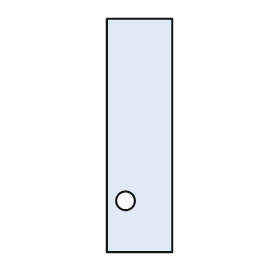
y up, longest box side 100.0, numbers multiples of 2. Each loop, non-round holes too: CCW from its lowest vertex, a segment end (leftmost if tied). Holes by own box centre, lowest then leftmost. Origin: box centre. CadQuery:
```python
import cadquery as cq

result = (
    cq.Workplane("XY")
    .moveTo(-14.0, -50.0)
    .lineTo(14.0, -50.0)
    .lineTo(14.0, 50.0)
    .lineTo(-14.0, 50.0)
    .close()
    .moveTo(-6.0, -28.0)
    .circle(4.0)
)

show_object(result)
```